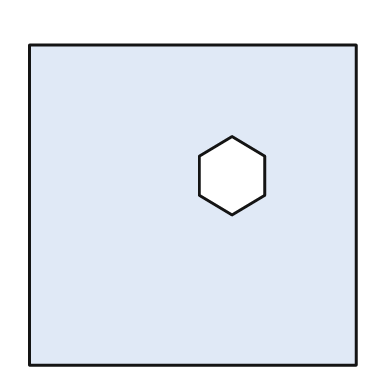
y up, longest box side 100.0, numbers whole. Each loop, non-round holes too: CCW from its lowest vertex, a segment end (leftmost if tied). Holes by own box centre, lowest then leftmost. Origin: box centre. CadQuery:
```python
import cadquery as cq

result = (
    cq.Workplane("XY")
    .moveTo(-50.0, -49.0)
    .lineTo(50.0, -49.0)
    .lineTo(50.0, 49.0)
    .lineTo(-50.0, 49.0)
    .close()
    .moveTo(12.0, -3.0)
    .lineTo(22.0, 3.0)
    .lineTo(22.0, 15.0)
    .lineTo(12.0, 21.0)
    .lineTo(2.0, 15.0)
    .lineTo(2.0, 3.0)
    .close()
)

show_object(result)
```